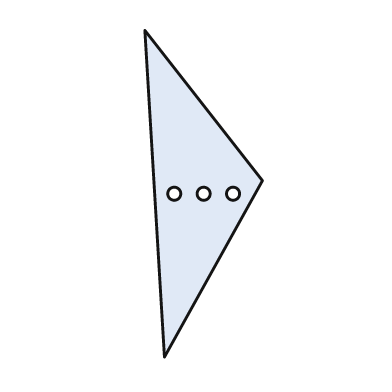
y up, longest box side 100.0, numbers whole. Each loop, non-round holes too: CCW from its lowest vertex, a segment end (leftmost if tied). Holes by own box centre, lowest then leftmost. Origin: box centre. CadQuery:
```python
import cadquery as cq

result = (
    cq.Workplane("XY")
    .moveTo(-12.0, -50.0)
    .lineTo(18.0, 4.0)
    .lineTo(-18.0, 50.0)
    .close()
    .moveTo(-9.0, 0.0)
    .circle(2.0)
    .moveTo(0.0, 0.0)
    .circle(2.0)
    .moveTo(9.0, 0.0)
    .circle(2.0)
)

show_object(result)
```